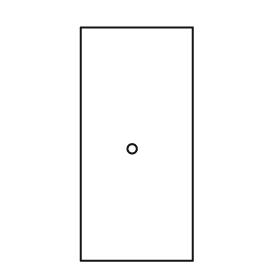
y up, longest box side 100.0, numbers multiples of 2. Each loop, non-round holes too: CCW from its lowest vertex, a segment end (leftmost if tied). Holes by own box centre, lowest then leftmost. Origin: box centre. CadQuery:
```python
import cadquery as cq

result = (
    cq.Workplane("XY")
    .moveTo(-24.0, -50.0)
    .lineTo(24.0, -50.0)
    .lineTo(24.0, 50.0)
    .lineTo(-24.0, 50.0)
    .close()
    .moveTo(-2.0, -2.0)
    .circle(2.0)
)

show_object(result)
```